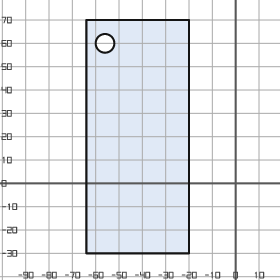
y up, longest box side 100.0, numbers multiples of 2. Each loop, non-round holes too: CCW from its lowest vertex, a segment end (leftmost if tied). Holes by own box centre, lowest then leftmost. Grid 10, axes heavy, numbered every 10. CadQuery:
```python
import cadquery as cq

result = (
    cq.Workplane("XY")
    .moveTo(-64.0, -30.0)
    .lineTo(-20.0, -30.0)
    .lineTo(-20.0, 70.0)
    .lineTo(-64.0, 70.0)
    .close()
    .moveTo(-56.0, 60.0)
    .circle(4.0)
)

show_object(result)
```